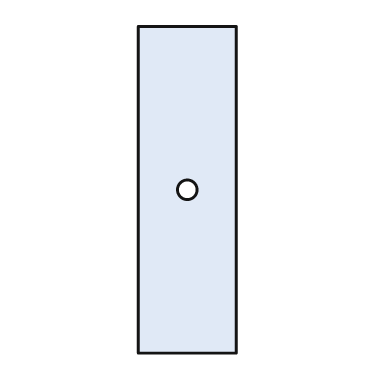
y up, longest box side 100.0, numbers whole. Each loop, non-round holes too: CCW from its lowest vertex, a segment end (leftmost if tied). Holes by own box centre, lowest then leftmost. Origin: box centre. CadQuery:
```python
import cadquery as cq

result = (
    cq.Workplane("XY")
    .moveTo(-15.0, -50.0)
    .lineTo(15.0, -50.0)
    .lineTo(15.0, 50.0)
    .lineTo(-15.0, 50.0)
    .close()
    .moveTo(0.0, 0.0)
    .circle(3.0)
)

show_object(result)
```